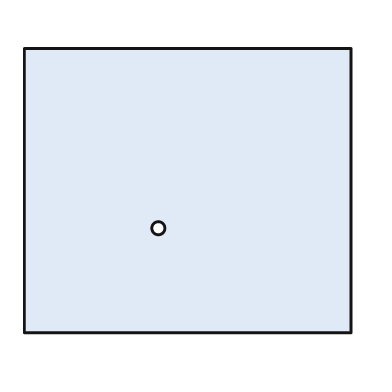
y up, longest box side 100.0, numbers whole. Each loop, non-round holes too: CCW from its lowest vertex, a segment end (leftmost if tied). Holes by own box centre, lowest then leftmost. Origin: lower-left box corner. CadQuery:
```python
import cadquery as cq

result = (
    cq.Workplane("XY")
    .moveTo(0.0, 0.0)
    .lineTo(100.0, 0.0)
    .lineTo(100.0, 87.0)
    .lineTo(0.0, 87.0)
    .close()
    .moveTo(41.0, 32.0)
    .circle(2.0)
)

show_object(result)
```